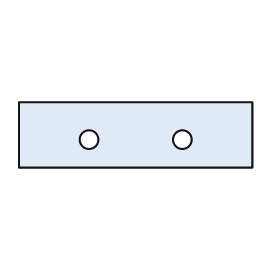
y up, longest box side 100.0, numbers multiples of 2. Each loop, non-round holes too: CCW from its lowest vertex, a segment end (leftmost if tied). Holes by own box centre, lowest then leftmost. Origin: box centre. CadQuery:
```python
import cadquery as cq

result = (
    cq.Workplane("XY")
    .moveTo(-50.0, -14.0)
    .lineTo(50.0, -14.0)
    .lineTo(50.0, 14.0)
    .lineTo(-50.0, 14.0)
    .close()
    .moveTo(-20.0, -2.0)
    .circle(4.0)
    .moveTo(20.0, -2.0)
    .circle(4.0)
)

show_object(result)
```